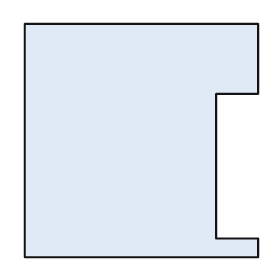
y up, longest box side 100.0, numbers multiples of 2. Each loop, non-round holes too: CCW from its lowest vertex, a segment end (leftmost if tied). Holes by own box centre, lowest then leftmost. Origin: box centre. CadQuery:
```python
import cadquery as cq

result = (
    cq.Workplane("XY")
    .moveTo(-50.0, -50.0)
    .lineTo(50.0, -50.0)
    .lineTo(50.0, -42.0)
    .lineTo(32.0, -42.0)
    .lineTo(32.0, 20.0)
    .lineTo(50.0, 20.0)
    .lineTo(50.0, 50.0)
    .lineTo(-50.0, 50.0)
    .close()
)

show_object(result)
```